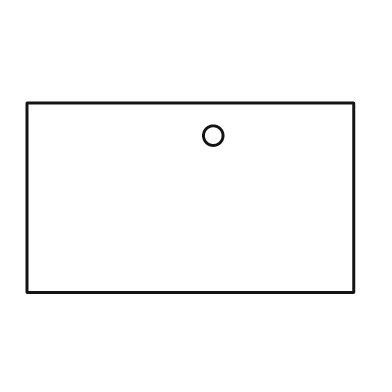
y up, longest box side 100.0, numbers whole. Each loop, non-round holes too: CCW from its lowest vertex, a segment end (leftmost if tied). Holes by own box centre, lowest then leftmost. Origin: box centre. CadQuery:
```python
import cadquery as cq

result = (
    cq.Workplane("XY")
    .moveTo(-50.0, -29.0)
    .lineTo(50.0, -29.0)
    .lineTo(50.0, 29.0)
    .lineTo(-50.0, 29.0)
    .close()
    .moveTo(7.0, 19.0)
    .circle(3.0)
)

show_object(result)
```